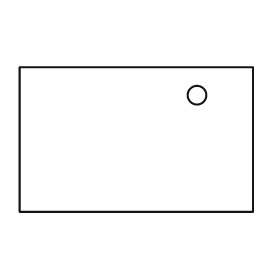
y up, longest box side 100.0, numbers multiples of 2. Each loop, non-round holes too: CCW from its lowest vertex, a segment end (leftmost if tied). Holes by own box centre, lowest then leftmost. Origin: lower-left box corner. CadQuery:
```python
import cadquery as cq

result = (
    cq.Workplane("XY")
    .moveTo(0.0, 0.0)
    .lineTo(100.0, 0.0)
    .lineTo(100.0, 62.0)
    .lineTo(0.0, 62.0)
    .close()
    .moveTo(76.0, 50.0)
    .circle(4.0)
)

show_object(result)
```